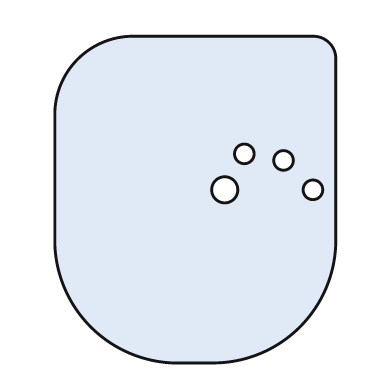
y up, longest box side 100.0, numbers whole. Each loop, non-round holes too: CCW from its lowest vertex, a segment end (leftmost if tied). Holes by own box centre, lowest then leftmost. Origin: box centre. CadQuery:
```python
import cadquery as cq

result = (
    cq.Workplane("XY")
    .moveTo(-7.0, -50.0)
    .lineTo(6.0, -50.0)
    .threePointArc((32.0, -39.0), (43.0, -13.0))
    .lineTo(43.0, 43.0)
    .threePointArc((41.0, 48.0), (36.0, 50.0))
    .lineTo(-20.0, 50.0)
    .threePointArc((-36.0, 43.0), (-43.0, 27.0))
    .lineTo(-43.0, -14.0)
    .threePointArc((-32.0, -39.0), (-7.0, -50.0))
    .close()
    .moveTo(9.0, 3.0)
    .circle(4.0)
    .moveTo(36.0, 3.0)
    .circle(3.0)
    .moveTo(27.0, 12.0)
    .circle(3.0)
    .moveTo(15.0, 14.0)
    .circle(3.0)
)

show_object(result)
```